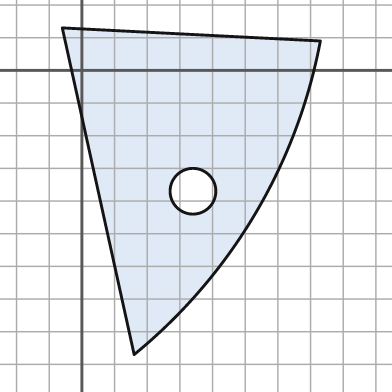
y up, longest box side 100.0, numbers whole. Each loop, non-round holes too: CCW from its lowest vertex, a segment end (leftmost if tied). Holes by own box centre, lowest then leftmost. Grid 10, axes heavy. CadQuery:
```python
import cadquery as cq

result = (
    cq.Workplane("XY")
    .moveTo(16.0, -87.0)
    .threePointArc((53.0, -44.0), (73.0, 9.0))
    .lineTo(-6.0, 13.0)
    .close()
    .moveTo(34.0, -37.0)
    .circle(7.0)
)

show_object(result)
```